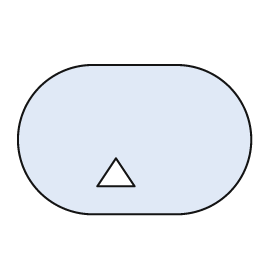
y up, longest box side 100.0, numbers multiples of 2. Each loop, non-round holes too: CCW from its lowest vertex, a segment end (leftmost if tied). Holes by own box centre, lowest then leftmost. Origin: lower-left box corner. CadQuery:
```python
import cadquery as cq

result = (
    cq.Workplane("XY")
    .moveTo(32.0, 0.0)
    .lineTo(68.0, 0.0)
    .threePointArc((100.0, 32.0), (68.0, 64.0))
    .lineTo(32.0, 64.0)
    .threePointArc((0.0, 32.0), (32.0, 0.0))
    .close()
    .moveTo(34.0, 12.0)
    .lineTo(50.0, 12.0)
    .lineTo(42.0, 24.0)
    .close()
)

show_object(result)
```